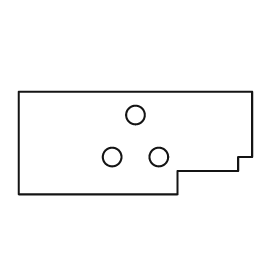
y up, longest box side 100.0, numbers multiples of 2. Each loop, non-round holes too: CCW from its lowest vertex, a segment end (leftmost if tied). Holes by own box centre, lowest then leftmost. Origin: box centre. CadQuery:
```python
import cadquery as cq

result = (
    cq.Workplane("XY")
    .moveTo(-50.0, -22.0)
    .lineTo(18.0, -22.0)
    .lineTo(18.0, -12.0)
    .lineTo(44.0, -12.0)
    .lineTo(44.0, -6.0)
    .lineTo(50.0, -6.0)
    .lineTo(50.0, 22.0)
    .lineTo(-50.0, 22.0)
    .close()
    .moveTo(-10.0, -6.0)
    .circle(4.0)
    .moveTo(10.0, -6.0)
    .circle(4.0)
    .moveTo(0.0, 12.0)
    .circle(4.0)
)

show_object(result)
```